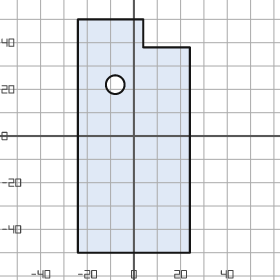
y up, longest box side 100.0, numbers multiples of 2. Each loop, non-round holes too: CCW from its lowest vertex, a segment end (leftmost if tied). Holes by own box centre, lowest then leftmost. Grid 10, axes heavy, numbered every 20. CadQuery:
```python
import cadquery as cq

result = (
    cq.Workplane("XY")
    .moveTo(-24.0, -50.0)
    .lineTo(24.0, -50.0)
    .lineTo(24.0, 38.0)
    .lineTo(4.0, 38.0)
    .lineTo(4.0, 50.0)
    .lineTo(-24.0, 50.0)
    .close()
    .moveTo(-8.0, 22.0)
    .circle(4.0)
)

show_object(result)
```